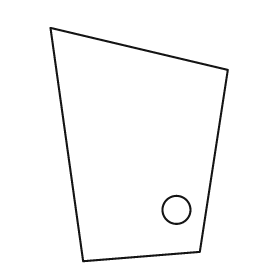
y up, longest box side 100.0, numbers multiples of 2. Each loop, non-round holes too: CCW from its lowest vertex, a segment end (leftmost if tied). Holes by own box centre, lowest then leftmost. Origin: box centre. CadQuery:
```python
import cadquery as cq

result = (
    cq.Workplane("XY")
    .moveTo(-24.0, -50.0)
    .lineTo(26.0, -46.0)
    .lineTo(38.0, 32.0)
    .lineTo(-38.0, 50.0)
    .close()
    .moveTo(16.0, -28.0)
    .circle(6.0)
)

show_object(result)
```